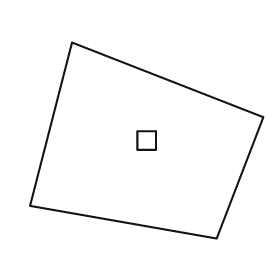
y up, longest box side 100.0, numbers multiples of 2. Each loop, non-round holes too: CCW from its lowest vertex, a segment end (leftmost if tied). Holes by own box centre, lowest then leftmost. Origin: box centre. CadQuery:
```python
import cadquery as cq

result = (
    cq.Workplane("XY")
    .moveTo(30.0, -42.0)
    .lineTo(50.0, 10.0)
    .lineTo(-32.0, 42.0)
    .lineTo(-50.0, -28.0)
    .close()
    .moveTo(-4.0, -4.0)
    .lineTo(4.0, -4.0)
    .lineTo(4.0, 4.0)
    .lineTo(-4.0, 4.0)
    .close()
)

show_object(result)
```